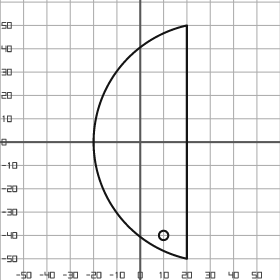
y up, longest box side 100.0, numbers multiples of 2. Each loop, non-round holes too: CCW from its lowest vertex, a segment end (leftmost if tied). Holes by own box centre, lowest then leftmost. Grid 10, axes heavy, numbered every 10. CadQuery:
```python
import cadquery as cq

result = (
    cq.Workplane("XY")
    .moveTo(20.0, -50.0)
    .lineTo(20.0, 50.0)
    .threePointArc((-20.0, 0.0), (20.0, -50.0))
    .close()
    .moveTo(10.0, -40.0)
    .circle(2.0)
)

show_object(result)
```